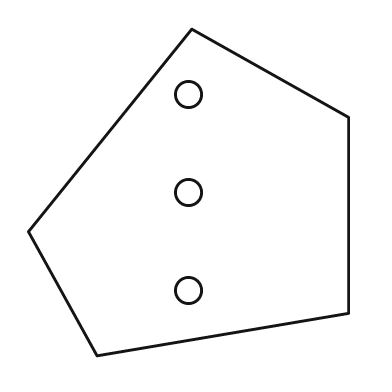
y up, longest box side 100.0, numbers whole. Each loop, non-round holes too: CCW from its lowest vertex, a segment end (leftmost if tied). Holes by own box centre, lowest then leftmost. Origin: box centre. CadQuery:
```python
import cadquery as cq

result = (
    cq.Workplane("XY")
    .moveTo(-28.0, -50.0)
    .lineTo(49.0, -37.0)
    .lineTo(49.0, 23.0)
    .lineTo(1.0, 50.0)
    .lineTo(-49.0, -12.0)
    .close()
    .moveTo(0.0, -30.0)
    .circle(4.0)
    .moveTo(0.0, 0.0)
    .circle(4.0)
    .moveTo(0.0, 30.0)
    .circle(4.0)
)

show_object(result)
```